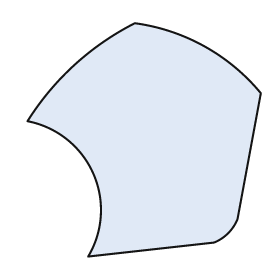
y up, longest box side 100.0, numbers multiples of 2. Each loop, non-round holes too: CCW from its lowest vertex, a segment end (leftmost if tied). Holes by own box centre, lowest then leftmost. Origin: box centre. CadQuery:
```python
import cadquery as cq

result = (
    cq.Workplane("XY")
    .moveTo(-24.0, -50.0)
    .lineTo(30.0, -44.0)
    .threePointArc((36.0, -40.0), (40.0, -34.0))
    .lineTo(50.0, 20.0)
    .threePointArc((26.0, 40.0), (-4.0, 50.0))
    .threePointArc((-30.0, 32.0), (-50.0, 8.0))
    .threePointArc((-22.0, -14.0), (-24.0, -50.0))
    .close()
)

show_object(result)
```